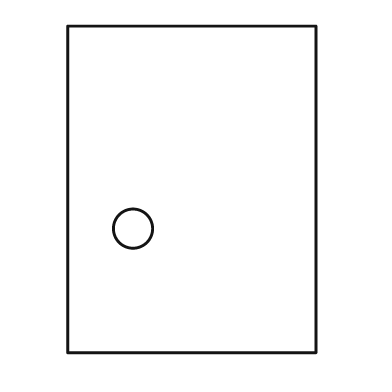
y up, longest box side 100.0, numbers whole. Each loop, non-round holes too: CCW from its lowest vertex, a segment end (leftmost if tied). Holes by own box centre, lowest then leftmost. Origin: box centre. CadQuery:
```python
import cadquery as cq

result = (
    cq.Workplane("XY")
    .moveTo(-38.0, -50.0)
    .lineTo(38.0, -50.0)
    .lineTo(38.0, 50.0)
    .lineTo(-38.0, 50.0)
    .close()
    .moveTo(-18.0, -12.0)
    .circle(6.0)
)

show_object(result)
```